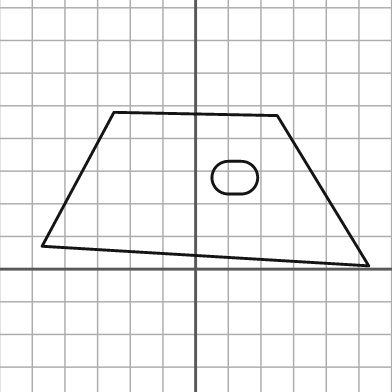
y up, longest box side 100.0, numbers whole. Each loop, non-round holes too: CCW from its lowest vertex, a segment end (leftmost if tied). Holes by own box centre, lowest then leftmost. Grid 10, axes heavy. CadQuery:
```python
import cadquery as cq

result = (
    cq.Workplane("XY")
    .moveTo(53.0, 1.0)
    .lineTo(25.0, 47.0)
    .lineTo(-25.0, 48.0)
    .lineTo(-47.0, 7.0)
    .close()
    .moveTo(10.0, 23.0)
    .lineTo(14.0, 23.0)
    .threePointArc((19.0, 28.0), (14.0, 33.0))
    .lineTo(10.0, 33.0)
    .threePointArc((5.0, 28.0), (10.0, 23.0))
    .close()
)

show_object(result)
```